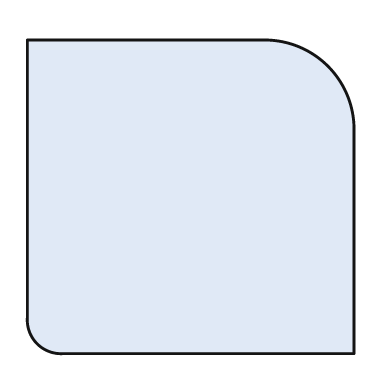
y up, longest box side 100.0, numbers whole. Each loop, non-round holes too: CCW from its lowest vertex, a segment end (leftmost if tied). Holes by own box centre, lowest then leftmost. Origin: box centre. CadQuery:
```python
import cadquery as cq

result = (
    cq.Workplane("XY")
    .moveTo(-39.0, -48.0)
    .lineTo(50.0, -48.0)
    .lineTo(50.0, 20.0)
    .threePointArc((42.0, 40.0), (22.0, 48.0))
    .lineTo(-50.0, 48.0)
    .lineTo(-50.0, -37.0)
    .threePointArc((-47.0, -45.0), (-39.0, -48.0))
    .close()
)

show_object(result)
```